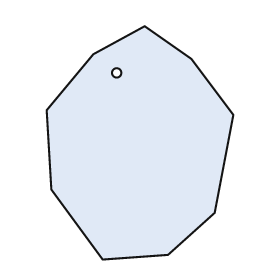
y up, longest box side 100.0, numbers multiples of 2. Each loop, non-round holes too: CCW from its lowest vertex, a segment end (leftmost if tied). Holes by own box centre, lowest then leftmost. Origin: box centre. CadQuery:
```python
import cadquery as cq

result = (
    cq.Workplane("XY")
    .moveTo(-16.0, -50.0)
    .lineTo(12.0, -48.0)
    .lineTo(32.0, -30.0)
    .lineTo(40.0, 12.0)
    .lineTo(22.0, 36.0)
    .lineTo(2.0, 50.0)
    .lineTo(-20.0, 38.0)
    .lineTo(-40.0, 14.0)
    .lineTo(-38.0, -20.0)
    .close()
    .moveTo(-10.0, 30.0)
    .circle(2.0)
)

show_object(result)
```